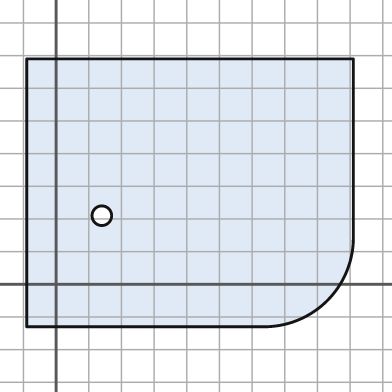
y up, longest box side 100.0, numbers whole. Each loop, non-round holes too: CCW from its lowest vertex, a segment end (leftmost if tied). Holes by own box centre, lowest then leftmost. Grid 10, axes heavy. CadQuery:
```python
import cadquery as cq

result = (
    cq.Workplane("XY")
    .moveTo(-9.0, -13.0)
    .lineTo(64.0, -13.0)
    .threePointArc((83.0, -5.0), (91.0, 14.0))
    .lineTo(91.0, 69.0)
    .lineTo(-9.0, 69.0)
    .close()
    .moveTo(14.0, 21.0)
    .circle(3.0)
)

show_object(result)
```